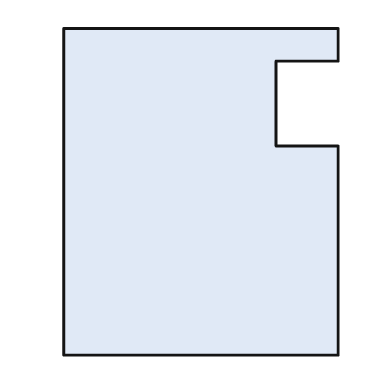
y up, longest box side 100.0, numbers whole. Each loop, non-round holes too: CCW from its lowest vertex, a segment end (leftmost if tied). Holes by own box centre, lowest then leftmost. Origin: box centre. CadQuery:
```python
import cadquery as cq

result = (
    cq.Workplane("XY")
    .moveTo(-42.0, -50.0)
    .lineTo(42.0, -50.0)
    .lineTo(42.0, 14.0)
    .lineTo(23.0, 14.0)
    .lineTo(23.0, 40.0)
    .lineTo(42.0, 40.0)
    .lineTo(42.0, 50.0)
    .lineTo(-42.0, 50.0)
    .close()
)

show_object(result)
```